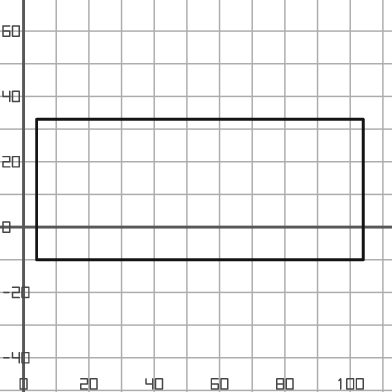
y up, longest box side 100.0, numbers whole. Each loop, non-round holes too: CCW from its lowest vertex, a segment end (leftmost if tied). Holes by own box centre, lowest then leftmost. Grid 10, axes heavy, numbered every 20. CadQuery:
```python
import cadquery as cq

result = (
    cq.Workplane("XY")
    .moveTo(4.0, -10.0)
    .lineTo(104.0, -10.0)
    .lineTo(104.0, 33.0)
    .lineTo(4.0, 33.0)
    .close()
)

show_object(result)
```